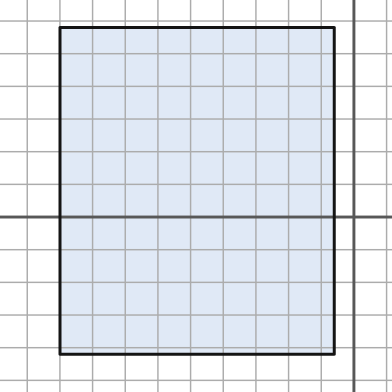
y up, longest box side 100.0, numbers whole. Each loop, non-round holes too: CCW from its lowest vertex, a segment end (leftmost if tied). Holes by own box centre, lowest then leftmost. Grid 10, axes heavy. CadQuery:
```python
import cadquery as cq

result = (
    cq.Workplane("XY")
    .moveTo(-90.0, -42.0)
    .lineTo(-6.0, -42.0)
    .lineTo(-6.0, 58.0)
    .lineTo(-90.0, 58.0)
    .close()
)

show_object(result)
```